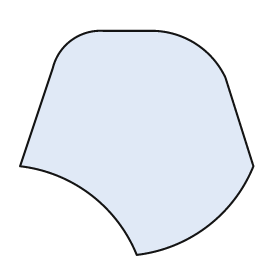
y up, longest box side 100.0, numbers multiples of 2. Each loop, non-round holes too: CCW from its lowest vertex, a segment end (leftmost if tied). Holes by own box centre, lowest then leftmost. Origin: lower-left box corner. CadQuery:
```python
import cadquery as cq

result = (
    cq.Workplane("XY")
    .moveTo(50.0, 0.0)
    .threePointArc((80.0, 12.0), (100.0, 38.0))
    .lineTo(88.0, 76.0)
    .threePointArc((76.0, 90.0), (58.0, 96.0))
    .lineTo(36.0, 96.0)
    .threePointArc((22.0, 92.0), (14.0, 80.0))
    .lineTo(0.0, 38.0)
    .threePointArc((30.0, 26.0), (50.0, 0.0))
    .close()
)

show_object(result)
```